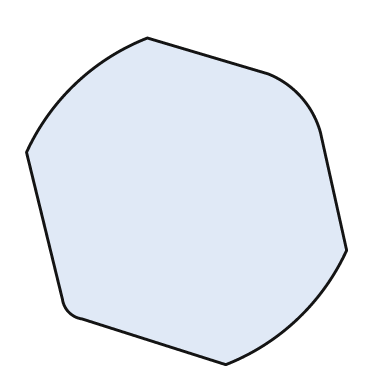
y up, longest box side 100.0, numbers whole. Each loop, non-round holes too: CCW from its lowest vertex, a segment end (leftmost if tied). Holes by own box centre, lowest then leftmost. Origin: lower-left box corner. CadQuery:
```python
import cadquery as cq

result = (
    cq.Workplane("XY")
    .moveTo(61.0, 0.0)
    .threePointArc((83.0, 14.0), (98.0, 35.0))
    .lineTo(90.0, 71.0)
    .threePointArc((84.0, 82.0), (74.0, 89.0))
    .lineTo(37.0, 100.0)
    .threePointArc((15.0, 86.0), (0.0, 65.0))
    .lineTo(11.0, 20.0)
    .threePointArc((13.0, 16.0), (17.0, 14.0))
    .close()
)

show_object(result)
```